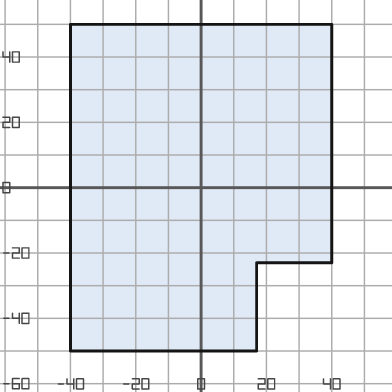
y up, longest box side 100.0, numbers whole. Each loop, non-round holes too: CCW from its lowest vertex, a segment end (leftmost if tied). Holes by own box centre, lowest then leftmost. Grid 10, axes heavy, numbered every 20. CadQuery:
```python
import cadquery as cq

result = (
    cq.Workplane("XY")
    .moveTo(-40.0, -50.0)
    .lineTo(17.0, -50.0)
    .lineTo(17.0, -23.0)
    .lineTo(40.0, -23.0)
    .lineTo(40.0, 50.0)
    .lineTo(-40.0, 50.0)
    .close()
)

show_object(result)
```